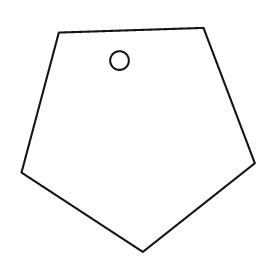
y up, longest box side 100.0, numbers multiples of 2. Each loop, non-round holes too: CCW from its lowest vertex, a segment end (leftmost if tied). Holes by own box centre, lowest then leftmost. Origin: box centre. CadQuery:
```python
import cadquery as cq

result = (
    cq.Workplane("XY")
    .moveTo(2.0, -48.0)
    .lineTo(50.0, -10.0)
    .lineTo(28.0, 48.0)
    .lineTo(-34.0, 46.0)
    .lineTo(-50.0, -14.0)
    .close()
    .moveTo(-8.0, 34.0)
    .circle(4.0)
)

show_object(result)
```